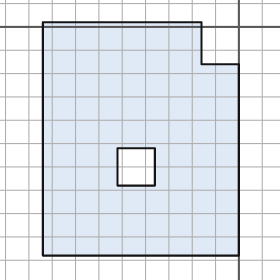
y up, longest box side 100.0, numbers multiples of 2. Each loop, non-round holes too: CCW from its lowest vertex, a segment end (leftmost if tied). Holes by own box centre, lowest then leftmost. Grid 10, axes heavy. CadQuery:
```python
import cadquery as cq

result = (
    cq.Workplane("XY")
    .moveTo(-84.0, -98.0)
    .lineTo(0.0, -98.0)
    .lineTo(0.0, -16.0)
    .lineTo(-16.0, -16.0)
    .lineTo(-16.0, 2.0)
    .lineTo(-84.0, 2.0)
    .close()
    .moveTo(-52.0, -68.0)
    .lineTo(-36.0, -68.0)
    .lineTo(-36.0, -52.0)
    .lineTo(-52.0, -52.0)
    .close()
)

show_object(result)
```